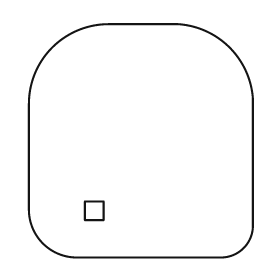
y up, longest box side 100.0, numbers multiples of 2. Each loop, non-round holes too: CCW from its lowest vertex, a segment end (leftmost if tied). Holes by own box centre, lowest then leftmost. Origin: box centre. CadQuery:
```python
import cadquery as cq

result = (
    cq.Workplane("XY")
    .moveTo(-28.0, -50.0)
    .lineTo(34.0, -50.0)
    .threePointArc((44.0, -46.0), (48.0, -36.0))
    .lineTo(48.0, 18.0)
    .threePointArc((38.0, 40.0), (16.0, 50.0))
    .lineTo(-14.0, 50.0)
    .threePointArc((-38.0, 40.0), (-48.0, 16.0))
    .lineTo(-48.0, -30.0)
    .threePointArc((-42.0, -44.0), (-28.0, -50.0))
    .close()
    .moveTo(-24.0, -34.0)
    .lineTo(-16.0, -34.0)
    .lineTo(-16.0, -26.0)
    .lineTo(-24.0, -26.0)
    .close()
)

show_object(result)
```